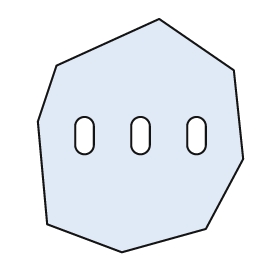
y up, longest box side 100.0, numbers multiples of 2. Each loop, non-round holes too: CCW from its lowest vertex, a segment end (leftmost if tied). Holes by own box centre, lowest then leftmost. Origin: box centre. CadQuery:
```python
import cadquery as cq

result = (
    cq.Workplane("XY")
    .moveTo(-8.0, -50.0)
    .lineTo(28.0, -40.0)
    .lineTo(44.0, -10.0)
    .lineTo(40.0, 28.0)
    .lineTo(8.0, 50.0)
    .lineTo(-36.0, 30.0)
    .lineTo(-44.0, 6.0)
    .lineTo(-40.0, -38.0)
    .close()
    .moveTo(-28.0, -4.0)
    .threePointArc((-24.0, -8.0), (-20.0, -4.0))
    .lineTo(-20.0, 4.0)
    .threePointArc((-24.0, 8.0), (-28.0, 4.0))
    .close()
    .moveTo(-4.0, -4.0)
    .threePointArc((0.0, -8.0), (4.0, -4.0))
    .lineTo(4.0, 4.0)
    .threePointArc((0.0, 8.0), (-4.0, 4.0))
    .close()
    .moveTo(20.0, -4.0)
    .threePointArc((24.0, -8.0), (28.0, -4.0))
    .lineTo(28.0, 4.0)
    .threePointArc((24.0, 8.0), (20.0, 4.0))
    .close()
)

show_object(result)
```